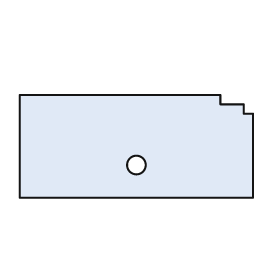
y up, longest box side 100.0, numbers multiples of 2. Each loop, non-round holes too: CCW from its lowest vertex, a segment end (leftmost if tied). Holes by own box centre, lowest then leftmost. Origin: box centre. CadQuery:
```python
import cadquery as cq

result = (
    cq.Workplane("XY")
    .moveTo(-50.0, -22.0)
    .lineTo(50.0, -22.0)
    .lineTo(50.0, 14.0)
    .lineTo(46.0, 14.0)
    .lineTo(46.0, 18.0)
    .lineTo(36.0, 18.0)
    .lineTo(36.0, 22.0)
    .lineTo(-50.0, 22.0)
    .close()
    .moveTo(0.0, -8.0)
    .circle(4.0)
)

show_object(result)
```